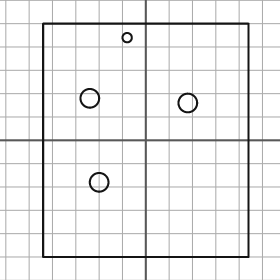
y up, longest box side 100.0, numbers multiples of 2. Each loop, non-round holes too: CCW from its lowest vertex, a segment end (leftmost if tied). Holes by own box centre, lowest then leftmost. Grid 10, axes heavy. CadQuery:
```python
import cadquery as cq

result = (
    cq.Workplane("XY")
    .moveTo(-44.0, -50.0)
    .lineTo(44.0, -50.0)
    .lineTo(44.0, 50.0)
    .lineTo(-44.0, 50.0)
    .close()
    .moveTo(-20.0, -18.0)
    .circle(4.0)
    .moveTo(18.0, 16.0)
    .circle(4.0)
    .moveTo(-24.0, 18.0)
    .circle(4.0)
    .moveTo(-8.0, 44.0)
    .circle(2.0)
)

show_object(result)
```